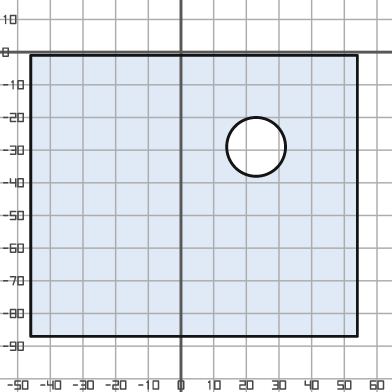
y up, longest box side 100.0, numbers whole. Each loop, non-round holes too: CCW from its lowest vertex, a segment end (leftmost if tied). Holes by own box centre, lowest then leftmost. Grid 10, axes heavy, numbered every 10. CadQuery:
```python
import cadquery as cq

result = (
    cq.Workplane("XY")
    .moveTo(-46.0, -87.0)
    .lineTo(54.0, -87.0)
    .lineTo(54.0, -1.0)
    .lineTo(-46.0, -1.0)
    .close()
    .moveTo(23.0, -29.0)
    .circle(9.0)
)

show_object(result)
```